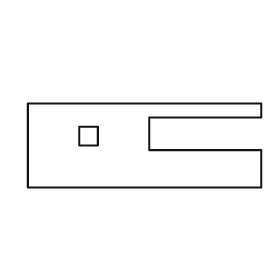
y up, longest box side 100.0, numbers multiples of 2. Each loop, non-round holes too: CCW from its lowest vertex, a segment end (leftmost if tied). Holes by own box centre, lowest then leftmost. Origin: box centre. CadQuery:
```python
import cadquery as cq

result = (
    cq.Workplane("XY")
    .moveTo(-50.0, -18.0)
    .lineTo(50.0, -18.0)
    .lineTo(50.0, -2.0)
    .lineTo(2.0, -2.0)
    .lineTo(2.0, 12.0)
    .lineTo(50.0, 12.0)
    .lineTo(50.0, 18.0)
    .lineTo(-50.0, 18.0)
    .close()
    .moveTo(-28.0, 0.0)
    .lineTo(-20.0, 0.0)
    .lineTo(-20.0, 8.0)
    .lineTo(-28.0, 8.0)
    .close()
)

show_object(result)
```